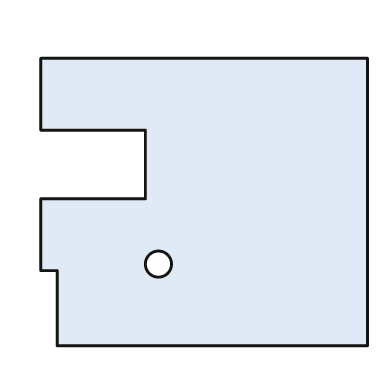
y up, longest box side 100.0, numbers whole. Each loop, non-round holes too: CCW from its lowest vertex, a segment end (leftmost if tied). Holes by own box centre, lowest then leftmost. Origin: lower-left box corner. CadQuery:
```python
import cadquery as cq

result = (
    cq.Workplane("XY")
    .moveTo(5.0, 0.0)
    .lineTo(100.0, 0.0)
    .lineTo(100.0, 88.0)
    .lineTo(0.0, 88.0)
    .lineTo(0.0, 66.0)
    .lineTo(32.0, 66.0)
    .lineTo(32.0, 45.0)
    .lineTo(0.0, 45.0)
    .lineTo(0.0, 23.0)
    .lineTo(5.0, 23.0)
    .close()
    .moveTo(36.0, 25.0)
    .circle(4.0)
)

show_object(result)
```